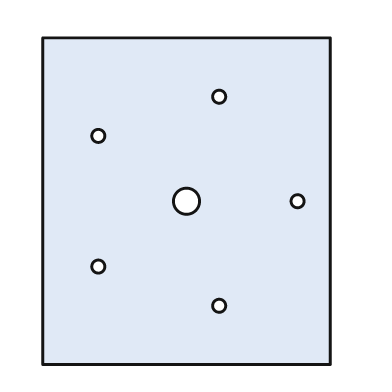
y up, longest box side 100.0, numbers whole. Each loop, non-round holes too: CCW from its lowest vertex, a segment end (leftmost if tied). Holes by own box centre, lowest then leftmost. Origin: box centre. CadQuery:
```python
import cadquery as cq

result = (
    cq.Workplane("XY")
    .moveTo(-44.0, -50.0)
    .lineTo(44.0, -50.0)
    .lineTo(44.0, 50.0)
    .lineTo(-44.0, 50.0)
    .close()
    .moveTo(10.0, -32.0)
    .circle(2.0)
    .moveTo(-27.0, -20.0)
    .circle(2.0)
    .moveTo(0.0, 0.0)
    .circle(4.0)
    .moveTo(34.0, 0.0)
    .circle(2.0)
    .moveTo(-27.0, 20.0)
    .circle(2.0)
    .moveTo(10.0, 32.0)
    .circle(2.0)
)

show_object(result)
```